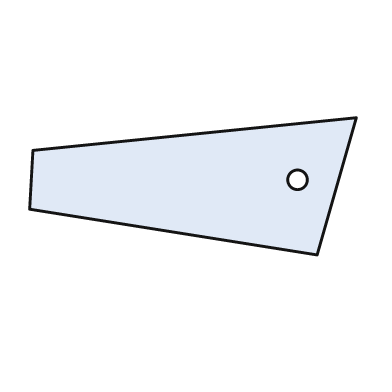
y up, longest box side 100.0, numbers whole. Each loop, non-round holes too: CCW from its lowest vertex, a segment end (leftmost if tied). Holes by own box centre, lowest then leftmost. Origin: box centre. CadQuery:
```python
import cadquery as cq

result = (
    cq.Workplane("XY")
    .moveTo(38.0, -21.0)
    .lineTo(50.0, 21.0)
    .lineTo(-49.0, 11.0)
    .lineTo(-50.0, -7.0)
    .close()
    .moveTo(32.0, 2.0)
    .circle(3.0)
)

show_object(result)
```